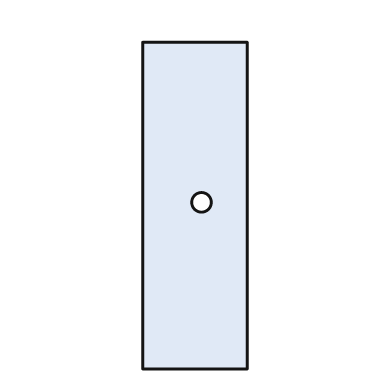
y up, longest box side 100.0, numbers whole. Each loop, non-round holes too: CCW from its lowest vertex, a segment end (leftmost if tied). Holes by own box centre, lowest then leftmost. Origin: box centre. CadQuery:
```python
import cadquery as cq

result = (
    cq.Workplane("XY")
    .moveTo(-16.0, -50.0)
    .lineTo(16.0, -50.0)
    .lineTo(16.0, 50.0)
    .lineTo(-16.0, 50.0)
    .close()
    .moveTo(2.0, 1.0)
    .circle(3.0)
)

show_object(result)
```